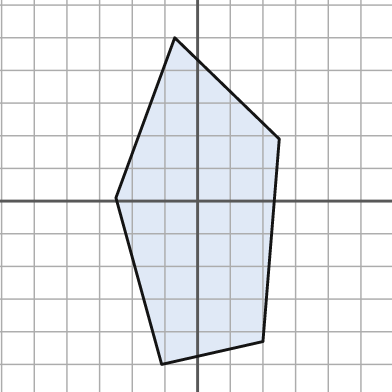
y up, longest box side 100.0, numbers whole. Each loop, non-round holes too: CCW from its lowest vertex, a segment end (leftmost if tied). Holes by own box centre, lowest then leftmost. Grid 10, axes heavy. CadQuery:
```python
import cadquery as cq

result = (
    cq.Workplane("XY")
    .moveTo(-11.0, -50.0)
    .lineTo(20.0, -43.0)
    .lineTo(25.0, 19.0)
    .lineTo(-7.0, 50.0)
    .lineTo(-25.0, 1.0)
    .close()
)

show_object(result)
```